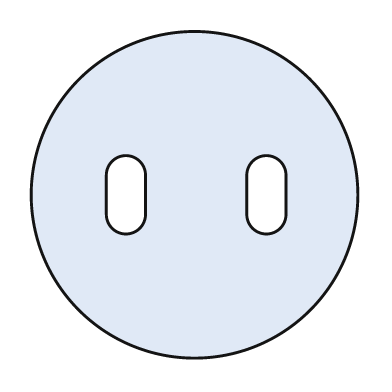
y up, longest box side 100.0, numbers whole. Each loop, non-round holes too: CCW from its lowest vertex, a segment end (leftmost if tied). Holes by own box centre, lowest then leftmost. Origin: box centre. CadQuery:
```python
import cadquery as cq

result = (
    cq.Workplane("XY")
    .moveTo(0.0, 0.0)
    .circle(50.0)
    .moveTo(-27.0, -6.0)
    .threePointArc((-21.0, -12.0), (-15.0, -6.0))
    .lineTo(-15.0, 6.0)
    .threePointArc((-21.0, 12.0), (-27.0, 6.0))
    .close()
    .moveTo(16.0, -6.0)
    .threePointArc((22.0, -12.0), (28.0, -6.0))
    .lineTo(28.0, 6.0)
    .threePointArc((22.0, 12.0), (16.0, 6.0))
    .close()
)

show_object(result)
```